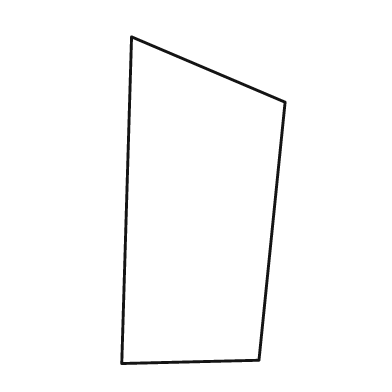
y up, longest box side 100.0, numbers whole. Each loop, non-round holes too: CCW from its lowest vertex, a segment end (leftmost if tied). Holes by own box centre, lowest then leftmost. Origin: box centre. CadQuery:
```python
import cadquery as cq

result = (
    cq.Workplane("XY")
    .moveTo(-25.0, -50.0)
    .lineTo(17.0, -49.0)
    .lineTo(25.0, 30.0)
    .lineTo(-22.0, 50.0)
    .close()
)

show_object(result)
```